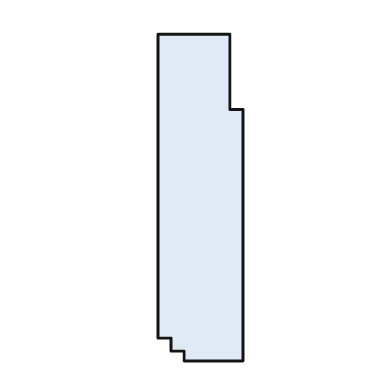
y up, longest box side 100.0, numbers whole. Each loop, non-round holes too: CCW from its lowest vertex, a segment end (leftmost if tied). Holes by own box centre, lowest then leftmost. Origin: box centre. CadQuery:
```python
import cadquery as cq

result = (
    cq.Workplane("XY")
    .moveTo(-5.0, -50.0)
    .lineTo(13.0, -50.0)
    .lineTo(13.0, 27.0)
    .lineTo(9.0, 27.0)
    .lineTo(9.0, 50.0)
    .lineTo(-13.0, 50.0)
    .lineTo(-13.0, -43.0)
    .lineTo(-9.0, -43.0)
    .lineTo(-9.0, -47.0)
    .lineTo(-5.0, -47.0)
    .close()
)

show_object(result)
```